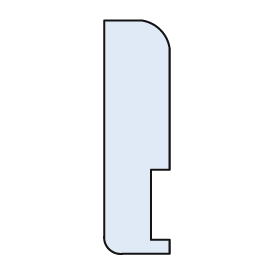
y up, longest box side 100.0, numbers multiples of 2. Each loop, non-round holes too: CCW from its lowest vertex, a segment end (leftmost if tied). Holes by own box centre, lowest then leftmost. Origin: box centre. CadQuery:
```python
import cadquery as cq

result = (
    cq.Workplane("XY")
    .moveTo(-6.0, -50.0)
    .lineTo(14.0, -50.0)
    .lineTo(14.0, -44.0)
    .lineTo(6.0, -44.0)
    .lineTo(6.0, -14.0)
    .lineTo(14.0, -14.0)
    .lineTo(14.0, 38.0)
    .threePointArc((10.0, 46.0), (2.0, 50.0))
    .lineTo(-14.0, 50.0)
    .lineTo(-14.0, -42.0)
    .threePointArc((-12.0, -48.0), (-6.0, -50.0))
    .close()
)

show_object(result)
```